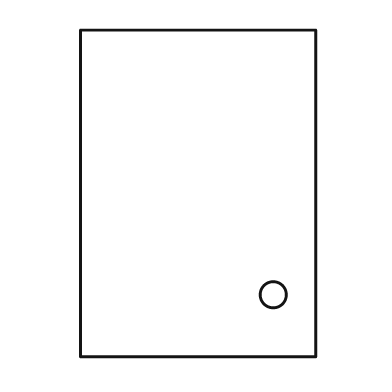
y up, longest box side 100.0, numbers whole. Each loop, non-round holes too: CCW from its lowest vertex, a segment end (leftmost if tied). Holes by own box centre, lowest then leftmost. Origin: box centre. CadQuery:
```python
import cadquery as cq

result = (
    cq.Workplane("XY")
    .moveTo(-36.0, -50.0)
    .lineTo(36.0, -50.0)
    .lineTo(36.0, 50.0)
    .lineTo(-36.0, 50.0)
    .close()
    .moveTo(23.0, -31.0)
    .circle(4.0)
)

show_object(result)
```